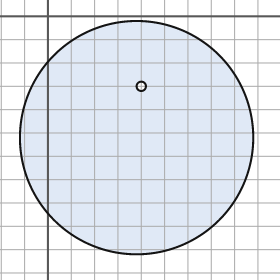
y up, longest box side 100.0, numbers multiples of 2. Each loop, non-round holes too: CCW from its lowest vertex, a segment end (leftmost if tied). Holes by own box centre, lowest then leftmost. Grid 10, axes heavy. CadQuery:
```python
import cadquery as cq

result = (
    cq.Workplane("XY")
    .moveTo(38.0, -52.0)
    .circle(50.0)
    .moveTo(40.0, -30.0)
    .circle(2.0)
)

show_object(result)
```